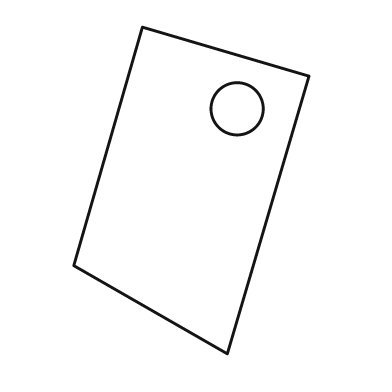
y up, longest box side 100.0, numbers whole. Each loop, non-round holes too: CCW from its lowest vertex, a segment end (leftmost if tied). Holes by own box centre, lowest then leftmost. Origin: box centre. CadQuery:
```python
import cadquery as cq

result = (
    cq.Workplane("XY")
    .moveTo(11.0, -50.0)
    .lineTo(36.0, 35.0)
    .lineTo(-15.0, 50.0)
    .lineTo(-36.0, -23.0)
    .close()
    .moveTo(14.0, 25.0)
    .circle(8.0)
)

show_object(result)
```